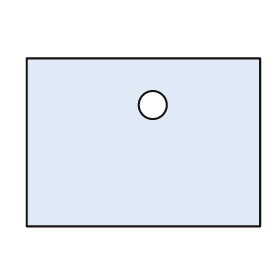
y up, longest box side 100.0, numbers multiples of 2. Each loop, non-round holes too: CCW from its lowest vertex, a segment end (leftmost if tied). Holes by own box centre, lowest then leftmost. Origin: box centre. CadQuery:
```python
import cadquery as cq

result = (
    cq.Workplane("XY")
    .moveTo(-50.0, -36.0)
    .lineTo(50.0, -36.0)
    .lineTo(50.0, 36.0)
    .lineTo(-50.0, 36.0)
    .close()
    .moveTo(4.0, 16.0)
    .circle(6.0)
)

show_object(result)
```